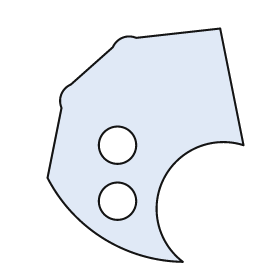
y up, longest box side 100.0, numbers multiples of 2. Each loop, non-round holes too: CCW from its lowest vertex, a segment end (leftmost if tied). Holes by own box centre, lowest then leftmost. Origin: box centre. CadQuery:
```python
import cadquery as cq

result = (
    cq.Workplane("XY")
    .moveTo(16.0, -50.0)
    .threePointArc((8.0, -14.0), (42.0, 0.0))
    .lineTo(32.0, 50.0)
    .lineTo(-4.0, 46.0)
    .threePointArc((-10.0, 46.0), (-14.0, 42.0))
    .lineTo(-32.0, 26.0)
    .threePointArc((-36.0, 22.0), (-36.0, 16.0))
    .lineTo(-42.0, -14.0)
    .threePointArc((-18.0, -40.0), (16.0, -50.0))
    .close()
    .moveTo(-12.0, -24.0)
    .circle(8.0)
    .moveTo(-12.0, 0.0)
    .circle(8.0)
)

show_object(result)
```